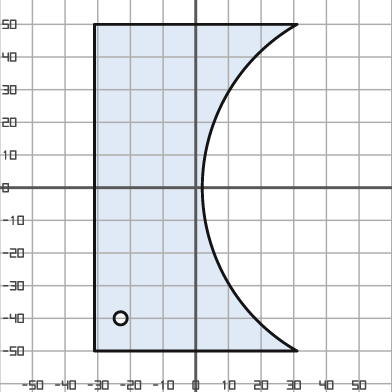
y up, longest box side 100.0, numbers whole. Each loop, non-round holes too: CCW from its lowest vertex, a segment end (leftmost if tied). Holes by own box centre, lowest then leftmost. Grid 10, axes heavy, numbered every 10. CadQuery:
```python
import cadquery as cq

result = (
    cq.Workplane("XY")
    .moveTo(-31.0, -50.0)
    .lineTo(31.0, -50.0)
    .threePointArc((2.0, 0.0), (31.0, 50.0))
    .lineTo(-31.0, 50.0)
    .close()
    .moveTo(-23.0, -40.0)
    .circle(2.0)
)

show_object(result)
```